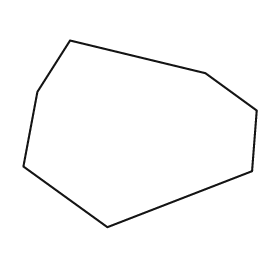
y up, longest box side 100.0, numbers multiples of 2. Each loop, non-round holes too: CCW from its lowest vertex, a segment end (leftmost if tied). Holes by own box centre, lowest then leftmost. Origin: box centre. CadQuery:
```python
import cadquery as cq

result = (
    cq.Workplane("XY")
    .moveTo(-14.0, -40.0)
    .lineTo(48.0, -16.0)
    .lineTo(50.0, 10.0)
    .lineTo(28.0, 26.0)
    .lineTo(-30.0, 40.0)
    .lineTo(-44.0, 18.0)
    .lineTo(-50.0, -14.0)
    .close()
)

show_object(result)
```